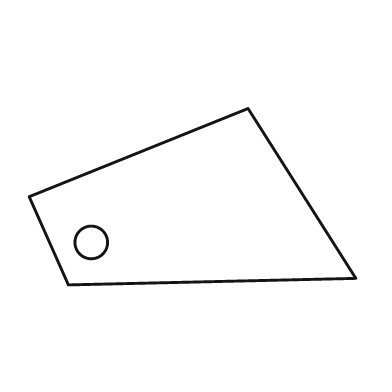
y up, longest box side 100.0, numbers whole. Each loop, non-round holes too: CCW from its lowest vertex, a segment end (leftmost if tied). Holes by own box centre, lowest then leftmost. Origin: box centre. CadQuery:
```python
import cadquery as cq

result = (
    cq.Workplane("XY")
    .moveTo(-38.0, -27.0)
    .lineTo(50.0, -25.0)
    .lineTo(17.0, 27.0)
    .lineTo(-50.0, 0.0)
    .close()
    .moveTo(-31.0, -14.0)
    .circle(5.0)
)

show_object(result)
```